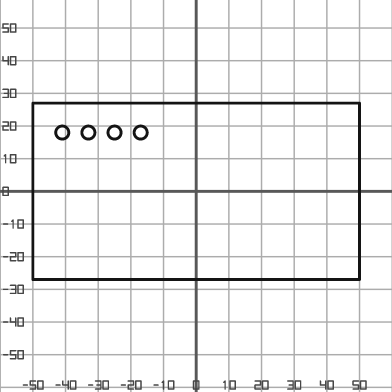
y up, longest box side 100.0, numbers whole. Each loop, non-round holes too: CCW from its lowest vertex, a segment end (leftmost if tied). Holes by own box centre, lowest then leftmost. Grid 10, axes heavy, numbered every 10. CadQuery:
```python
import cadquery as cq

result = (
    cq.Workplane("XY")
    .moveTo(-50.0, -27.0)
    .lineTo(50.0, -27.0)
    .lineTo(50.0, 27.0)
    .lineTo(-50.0, 27.0)
    .close()
    .moveTo(-41.0, 18.0)
    .circle(2.0)
    .moveTo(-33.0, 18.0)
    .circle(2.0)
    .moveTo(-25.0, 18.0)
    .circle(2.0)
    .moveTo(-17.0, 18.0)
    .circle(2.0)
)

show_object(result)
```